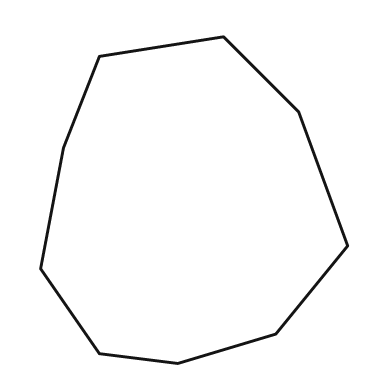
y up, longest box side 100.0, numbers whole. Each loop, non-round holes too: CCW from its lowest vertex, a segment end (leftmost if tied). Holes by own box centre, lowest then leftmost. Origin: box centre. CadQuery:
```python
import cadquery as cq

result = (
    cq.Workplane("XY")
    .moveTo(-5.0, -50.0)
    .lineTo(25.0, -41.0)
    .lineTo(47.0, -14.0)
    .lineTo(32.0, 27.0)
    .lineTo(9.0, 50.0)
    .lineTo(-29.0, 44.0)
    .lineTo(-40.0, 16.0)
    .lineTo(-47.0, -21.0)
    .lineTo(-29.0, -47.0)
    .close()
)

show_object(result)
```